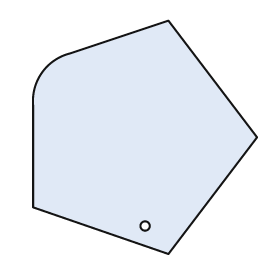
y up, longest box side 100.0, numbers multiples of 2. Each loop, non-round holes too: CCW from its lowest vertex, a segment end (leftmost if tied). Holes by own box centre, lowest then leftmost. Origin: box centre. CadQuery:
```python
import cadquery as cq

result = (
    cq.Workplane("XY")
    .moveTo(10.0, -50.0)
    .lineTo(48.0, 0.0)
    .lineTo(10.0, 50.0)
    .lineTo(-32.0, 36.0)
    .threePointArc((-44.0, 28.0), (-48.0, 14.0))
    .lineTo(-48.0, -30.0)
    .close()
    .moveTo(0.0, -38.0)
    .circle(2.0)
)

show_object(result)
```